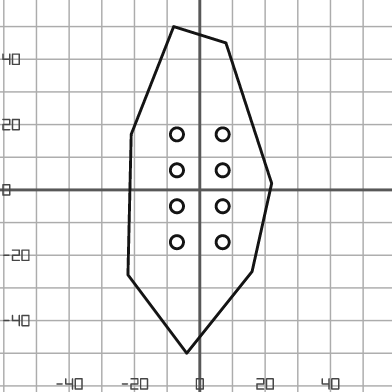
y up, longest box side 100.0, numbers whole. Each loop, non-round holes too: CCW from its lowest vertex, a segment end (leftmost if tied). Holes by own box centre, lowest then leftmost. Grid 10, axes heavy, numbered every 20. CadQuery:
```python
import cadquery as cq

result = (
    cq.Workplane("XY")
    .moveTo(-4.0, -50.0)
    .lineTo(16.0, -25.0)
    .lineTo(22.0, 2.0)
    .lineTo(8.0, 45.0)
    .lineTo(-8.0, 50.0)
    .lineTo(-21.0, 17.0)
    .lineTo(-22.0, -26.0)
    .close()
    .moveTo(-7.0, -16.0)
    .circle(2.0)
    .moveTo(7.0, -16.0)
    .circle(2.0)
    .moveTo(-7.0, -5.0)
    .circle(2.0)
    .moveTo(7.0, -5.0)
    .circle(2.0)
    .moveTo(-7.0, 6.0)
    .circle(2.0)
    .moveTo(7.0, 6.0)
    .circle(2.0)
    .moveTo(-7.0, 17.0)
    .circle(2.0)
    .moveTo(7.0, 17.0)
    .circle(2.0)
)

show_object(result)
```